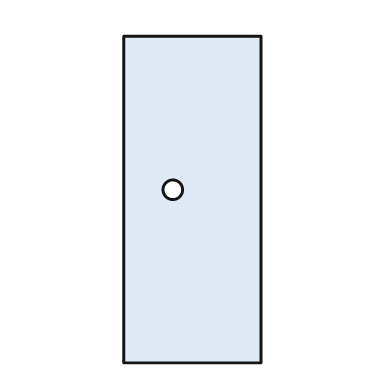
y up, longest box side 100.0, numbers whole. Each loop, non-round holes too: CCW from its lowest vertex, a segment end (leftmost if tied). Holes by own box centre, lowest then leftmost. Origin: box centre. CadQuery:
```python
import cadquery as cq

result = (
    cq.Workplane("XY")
    .moveTo(-21.0, -50.0)
    .lineTo(21.0, -50.0)
    .lineTo(21.0, 50.0)
    .lineTo(-21.0, 50.0)
    .close()
    .moveTo(-6.0, 3.0)
    .circle(3.0)
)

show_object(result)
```